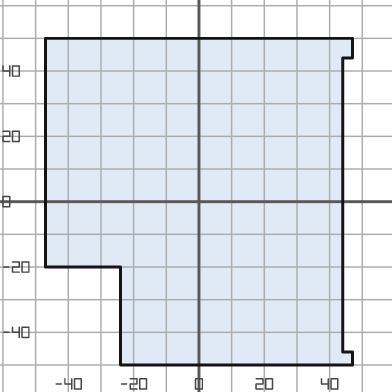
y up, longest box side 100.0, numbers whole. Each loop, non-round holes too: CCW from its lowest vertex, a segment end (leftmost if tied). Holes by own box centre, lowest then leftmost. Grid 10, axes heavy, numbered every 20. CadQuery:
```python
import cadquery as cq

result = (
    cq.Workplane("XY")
    .moveTo(-24.0, -50.0)
    .lineTo(47.0, -50.0)
    .lineTo(47.0, -46.0)
    .lineTo(44.0, -46.0)
    .lineTo(44.0, 44.0)
    .lineTo(47.0, 44.0)
    .lineTo(47.0, 50.0)
    .lineTo(-47.0, 50.0)
    .lineTo(-47.0, -20.0)
    .lineTo(-24.0, -20.0)
    .close()
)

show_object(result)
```